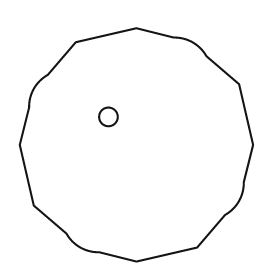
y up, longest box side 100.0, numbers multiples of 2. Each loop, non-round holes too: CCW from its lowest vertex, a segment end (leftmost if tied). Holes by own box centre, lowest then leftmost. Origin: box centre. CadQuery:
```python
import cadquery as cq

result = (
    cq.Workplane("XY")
    .moveTo(0.0, -50.0)
    .lineTo(26.0, -44.0)
    .lineTo(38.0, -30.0)
    .threePointArc((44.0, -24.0), (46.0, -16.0))
    .lineTo(50.0, 0.0)
    .lineTo(44.0, 26.0)
    .lineTo(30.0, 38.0)
    .threePointArc((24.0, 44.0), (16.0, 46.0))
    .lineTo(0.0, 50.0)
    .lineTo(-26.0, 44.0)
    .lineTo(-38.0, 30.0)
    .threePointArc((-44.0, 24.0), (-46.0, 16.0))
    .lineTo(-50.0, 0.0)
    .lineTo(-44.0, -26.0)
    .lineTo(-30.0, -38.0)
    .threePointArc((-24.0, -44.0), (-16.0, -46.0))
    .close()
    .moveTo(-12.0, 12.0)
    .circle(4.0)
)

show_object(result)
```